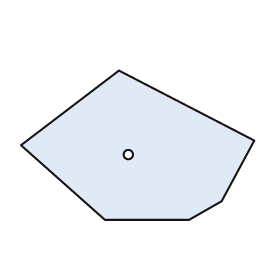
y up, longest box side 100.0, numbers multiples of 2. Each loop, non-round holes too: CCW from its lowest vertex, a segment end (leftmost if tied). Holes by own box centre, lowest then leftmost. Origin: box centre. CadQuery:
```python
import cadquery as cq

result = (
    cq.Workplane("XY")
    .moveTo(-14.0, -32.0)
    .lineTo(22.0, -32.0)
    .lineTo(36.0, -24.0)
    .lineTo(50.0, 2.0)
    .lineTo(-8.0, 32.0)
    .lineTo(-50.0, 0.0)
    .close()
    .moveTo(-4.0, -4.0)
    .circle(2.0)
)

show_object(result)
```